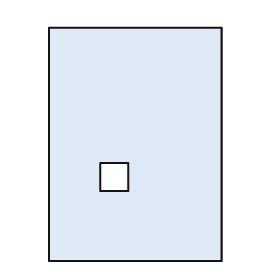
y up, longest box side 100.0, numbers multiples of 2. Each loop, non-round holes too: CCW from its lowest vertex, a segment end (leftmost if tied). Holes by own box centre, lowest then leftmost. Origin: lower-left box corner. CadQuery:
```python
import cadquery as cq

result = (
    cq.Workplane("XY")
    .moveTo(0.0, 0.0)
    .lineTo(74.0, 0.0)
    .lineTo(74.0, 100.0)
    .lineTo(0.0, 100.0)
    .close()
    .moveTo(22.0, 30.0)
    .lineTo(34.0, 30.0)
    .lineTo(34.0, 42.0)
    .lineTo(22.0, 42.0)
    .close()
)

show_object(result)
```